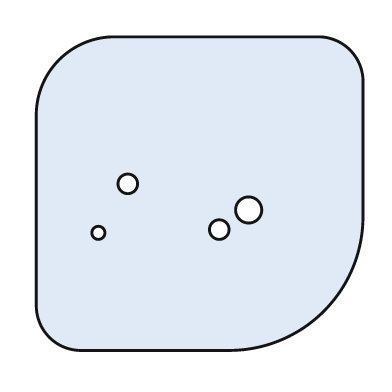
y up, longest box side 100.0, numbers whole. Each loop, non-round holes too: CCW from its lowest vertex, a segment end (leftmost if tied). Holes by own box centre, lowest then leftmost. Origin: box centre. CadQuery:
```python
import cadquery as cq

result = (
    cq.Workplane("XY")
    .moveTo(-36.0, -48.0)
    .lineTo(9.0, -48.0)
    .threePointArc((38.0, -36.0), (50.0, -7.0))
    .lineTo(50.0, 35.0)
    .threePointArc((46.0, 44.0), (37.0, 48.0))
    .lineTo(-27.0, 48.0)
    .threePointArc((-43.0, 41.0), (-50.0, 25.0))
    .lineTo(-50.0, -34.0)
    .threePointArc((-46.0, -44.0), (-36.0, -48.0))
    .close()
    .moveTo(-31.0, -12.0)
    .circle(2.0)
    .moveTo(6.0, -11.0)
    .circle(3.0)
    .moveTo(15.0, -5.0)
    .circle(4.0)
    .moveTo(-22.0, 3.0)
    .circle(3.0)
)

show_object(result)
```